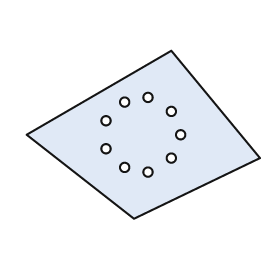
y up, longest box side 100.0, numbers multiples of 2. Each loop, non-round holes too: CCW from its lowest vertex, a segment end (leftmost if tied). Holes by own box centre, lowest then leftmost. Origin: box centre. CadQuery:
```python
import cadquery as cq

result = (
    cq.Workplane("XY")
    .moveTo(-4.0, -36.0)
    .lineTo(50.0, -10.0)
    .lineTo(12.0, 36.0)
    .lineTo(-50.0, 0.0)
    .close()
    .moveTo(2.0, -16.0)
    .circle(2.0)
    .moveTo(-8.0, -14.0)
    .circle(2.0)
    .moveTo(12.0, -10.0)
    .circle(2.0)
    .moveTo(-16.0, -6.0)
    .circle(2.0)
    .moveTo(16.0, 0.0)
    .circle(2.0)
    .moveTo(-16.0, 6.0)
    .circle(2.0)
    .moveTo(12.0, 10.0)
    .circle(2.0)
    .moveTo(-8.0, 14.0)
    .circle(2.0)
    .moveTo(2.0, 16.0)
    .circle(2.0)
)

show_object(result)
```